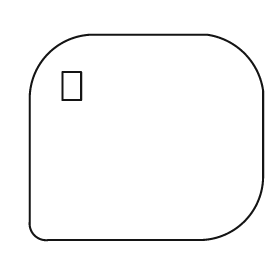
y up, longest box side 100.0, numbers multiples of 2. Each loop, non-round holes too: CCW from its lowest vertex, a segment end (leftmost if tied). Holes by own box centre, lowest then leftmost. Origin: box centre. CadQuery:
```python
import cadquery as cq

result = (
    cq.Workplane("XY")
    .moveTo(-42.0, -44.0)
    .lineTo(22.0, -44.0)
    .threePointArc((42.0, -36.0), (50.0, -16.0))
    .lineTo(50.0, 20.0)
    .threePointArc((42.0, 36.0), (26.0, 44.0))
    .lineTo(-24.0, 44.0)
    .threePointArc((-42.0, 36.0), (-50.0, 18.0))
    .lineTo(-50.0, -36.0)
    .threePointArc((-48.0, -42.0), (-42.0, -44.0))
    .close()
    .moveTo(-36.0, 16.0)
    .lineTo(-28.0, 16.0)
    .lineTo(-28.0, 28.0)
    .lineTo(-36.0, 28.0)
    .close()
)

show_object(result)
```